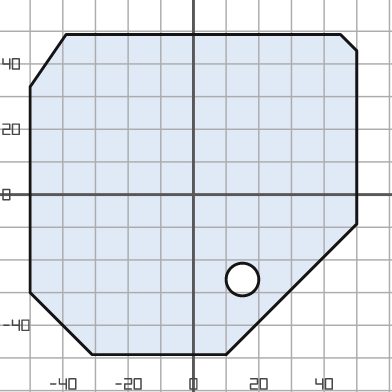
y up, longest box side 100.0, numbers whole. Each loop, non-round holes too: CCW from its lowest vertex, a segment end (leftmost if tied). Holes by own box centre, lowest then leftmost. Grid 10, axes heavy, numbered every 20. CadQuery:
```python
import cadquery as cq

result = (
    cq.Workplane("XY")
    .moveTo(-31.0, -49.0)
    .lineTo(10.0, -49.0)
    .lineTo(50.0, -9.0)
    .lineTo(50.0, 44.0)
    .lineTo(45.0, 49.0)
    .lineTo(-39.0, 49.0)
    .lineTo(-50.0, 33.0)
    .lineTo(-50.0, -30.0)
    .close()
    .moveTo(15.0, -26.0)
    .circle(5.0)
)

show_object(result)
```